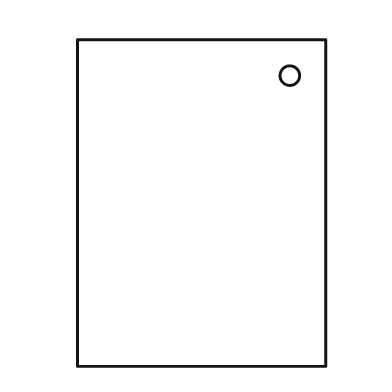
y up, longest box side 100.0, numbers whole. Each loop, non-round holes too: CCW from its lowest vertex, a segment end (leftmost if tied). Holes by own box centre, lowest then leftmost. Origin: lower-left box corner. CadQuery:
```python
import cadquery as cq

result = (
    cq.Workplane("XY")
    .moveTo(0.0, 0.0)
    .lineTo(76.0, 0.0)
    .lineTo(76.0, 100.0)
    .lineTo(0.0, 100.0)
    .close()
    .moveTo(65.0, 89.0)
    .circle(3.0)
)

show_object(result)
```